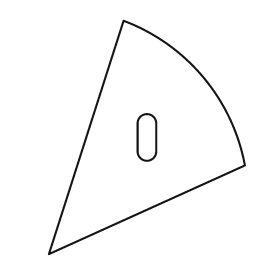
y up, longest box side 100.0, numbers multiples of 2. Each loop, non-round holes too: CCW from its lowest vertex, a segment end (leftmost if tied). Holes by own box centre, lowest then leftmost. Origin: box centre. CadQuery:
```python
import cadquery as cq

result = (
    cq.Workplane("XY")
    .moveTo(-42.0, -50.0)
    .lineTo(42.0, -12.0)
    .threePointArc((24.0, 26.0), (-10.0, 50.0))
    .close()
    .moveTo(-4.0, -6.0)
    .threePointArc((0.0, -10.0), (4.0, -6.0))
    .lineTo(4.0, 6.0)
    .threePointArc((0.0, 10.0), (-4.0, 6.0))
    .close()
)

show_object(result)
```